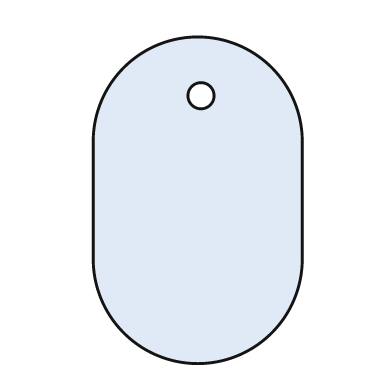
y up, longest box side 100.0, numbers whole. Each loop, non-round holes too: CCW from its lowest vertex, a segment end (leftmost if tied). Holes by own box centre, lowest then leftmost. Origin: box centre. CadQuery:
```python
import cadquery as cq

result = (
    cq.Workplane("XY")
    .moveTo(-32.0, -18.0)
    .threePointArc((0.0, -50.0), (32.0, -18.0))
    .lineTo(32.0, 18.0)
    .threePointArc((0.0, 50.0), (-32.0, 18.0))
    .close()
    .moveTo(1.0, 32.0)
    .circle(4.0)
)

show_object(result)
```